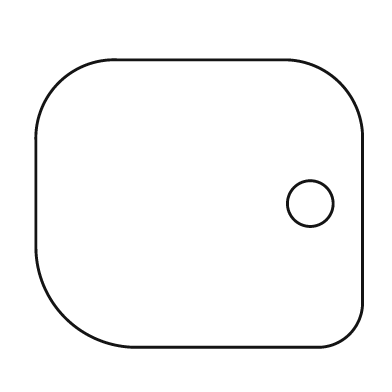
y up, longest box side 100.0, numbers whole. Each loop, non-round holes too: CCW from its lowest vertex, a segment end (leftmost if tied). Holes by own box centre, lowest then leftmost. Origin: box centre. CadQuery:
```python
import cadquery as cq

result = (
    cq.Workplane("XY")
    .moveTo(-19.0, -44.0)
    .lineTo(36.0, -44.0)
    .threePointArc((46.0, -40.0), (50.0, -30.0))
    .lineTo(50.0, 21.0)
    .threePointArc((43.0, 37.0), (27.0, 44.0))
    .lineTo(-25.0, 44.0)
    .threePointArc((-43.0, 37.0), (-50.0, 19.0))
    .lineTo(-50.0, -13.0)
    .threePointArc((-41.0, -35.0), (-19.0, -44.0))
    .close()
    .moveTo(34.0, 0.0)
    .circle(7.0)
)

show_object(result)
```